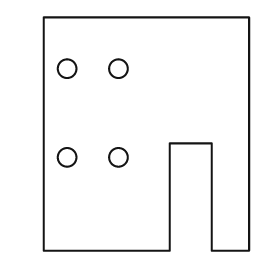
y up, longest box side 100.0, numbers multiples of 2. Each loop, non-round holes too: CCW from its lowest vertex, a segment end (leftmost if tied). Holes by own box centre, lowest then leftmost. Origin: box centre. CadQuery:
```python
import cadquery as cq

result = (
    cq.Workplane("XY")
    .moveTo(-44.0, -50.0)
    .lineTo(10.0, -50.0)
    .lineTo(10.0, -4.0)
    .lineTo(28.0, -4.0)
    .lineTo(28.0, -50.0)
    .lineTo(44.0, -50.0)
    .lineTo(44.0, 50.0)
    .lineTo(-44.0, 50.0)
    .close()
    .moveTo(-34.0, -10.0)
    .circle(4.0)
    .moveTo(-12.0, -10.0)
    .circle(4.0)
    .moveTo(-34.0, 28.0)
    .circle(4.0)
    .moveTo(-12.0, 28.0)
    .circle(4.0)
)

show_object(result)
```